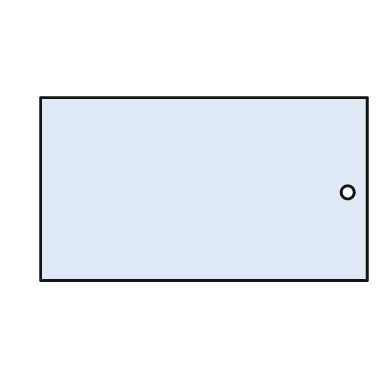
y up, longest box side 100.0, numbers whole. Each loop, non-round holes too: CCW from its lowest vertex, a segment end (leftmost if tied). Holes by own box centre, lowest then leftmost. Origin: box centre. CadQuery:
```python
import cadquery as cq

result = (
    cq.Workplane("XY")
    .moveTo(-50.0, -28.0)
    .lineTo(50.0, -28.0)
    .lineTo(50.0, 28.0)
    .lineTo(-50.0, 28.0)
    .close()
    .moveTo(44.0, -1.0)
    .circle(2.0)
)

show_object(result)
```